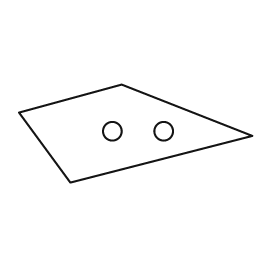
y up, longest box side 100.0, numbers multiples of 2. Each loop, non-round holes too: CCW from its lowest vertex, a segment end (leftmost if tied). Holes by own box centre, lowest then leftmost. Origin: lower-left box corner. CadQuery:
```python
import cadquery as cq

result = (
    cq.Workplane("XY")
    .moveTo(22.0, 0.0)
    .lineTo(100.0, 20.0)
    .lineTo(44.0, 42.0)
    .lineTo(0.0, 30.0)
    .close()
    .moveTo(40.0, 22.0)
    .circle(4.0)
    .moveTo(62.0, 22.0)
    .circle(4.0)
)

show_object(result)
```